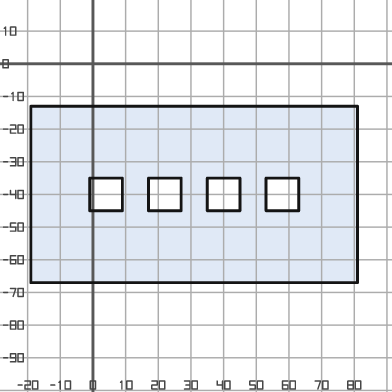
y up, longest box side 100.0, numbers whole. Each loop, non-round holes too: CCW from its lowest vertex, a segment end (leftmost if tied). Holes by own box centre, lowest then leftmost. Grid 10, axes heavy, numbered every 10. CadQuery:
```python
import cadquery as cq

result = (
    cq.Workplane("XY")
    .moveTo(-19.0, -67.0)
    .lineTo(81.0, -67.0)
    .lineTo(81.0, -13.0)
    .lineTo(-19.0, -13.0)
    .close()
    .moveTo(-1.0, -45.0)
    .lineTo(9.0, -45.0)
    .lineTo(9.0, -35.0)
    .lineTo(-1.0, -35.0)
    .close()
    .moveTo(17.0, -45.0)
    .lineTo(27.0, -45.0)
    .lineTo(27.0, -35.0)
    .lineTo(17.0, -35.0)
    .close()
    .moveTo(35.0, -45.0)
    .lineTo(45.0, -45.0)
    .lineTo(45.0, -35.0)
    .lineTo(35.0, -35.0)
    .close()
    .moveTo(53.0, -45.0)
    .lineTo(63.0, -45.0)
    .lineTo(63.0, -35.0)
    .lineTo(53.0, -35.0)
    .close()
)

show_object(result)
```